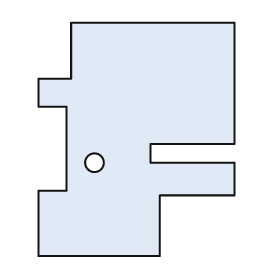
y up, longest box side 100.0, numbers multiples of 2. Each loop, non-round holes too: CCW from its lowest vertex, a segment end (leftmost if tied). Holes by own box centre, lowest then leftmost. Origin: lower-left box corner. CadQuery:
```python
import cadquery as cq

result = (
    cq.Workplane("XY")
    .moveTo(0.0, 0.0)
    .lineTo(52.0, 0.0)
    .lineTo(52.0, 26.0)
    .lineTo(84.0, 26.0)
    .lineTo(84.0, 40.0)
    .lineTo(48.0, 40.0)
    .lineTo(48.0, 48.0)
    .lineTo(84.0, 48.0)
    .lineTo(84.0, 100.0)
    .lineTo(14.0, 100.0)
    .lineTo(14.0, 76.0)
    .lineTo(0.0, 76.0)
    .lineTo(0.0, 64.0)
    .lineTo(12.0, 64.0)
    .lineTo(12.0, 28.0)
    .lineTo(0.0, 28.0)
    .close()
    .moveTo(24.0, 40.0)
    .circle(4.0)
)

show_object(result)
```